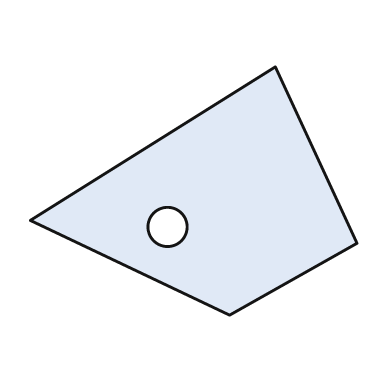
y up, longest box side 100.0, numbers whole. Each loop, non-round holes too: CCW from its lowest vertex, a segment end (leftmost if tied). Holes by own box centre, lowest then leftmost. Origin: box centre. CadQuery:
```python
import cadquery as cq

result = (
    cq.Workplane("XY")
    .moveTo(11.0, -38.0)
    .lineTo(50.0, -16.0)
    .lineTo(25.0, 38.0)
    .lineTo(-50.0, -9.0)
    .close()
    .moveTo(-8.0, -11.0)
    .circle(6.0)
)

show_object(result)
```